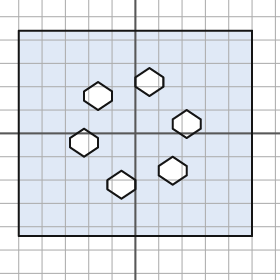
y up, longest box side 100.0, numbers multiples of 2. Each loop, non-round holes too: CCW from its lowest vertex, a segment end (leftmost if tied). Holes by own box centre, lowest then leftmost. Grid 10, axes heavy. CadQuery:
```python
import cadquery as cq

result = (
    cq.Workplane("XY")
    .moveTo(-50.0, -44.0)
    .lineTo(50.0, -44.0)
    .lineTo(50.0, 44.0)
    .lineTo(-50.0, 44.0)
    .close()
    .moveTo(-6.0, -28.0)
    .lineTo(0.0, -24.0)
    .lineTo(0.0, -20.0)
    .lineTo(-6.0, -16.0)
    .lineTo(-12.0, -20.0)
    .lineTo(-12.0, -24.0)
    .close()
    .moveTo(16.0, -22.0)
    .lineTo(22.0, -18.0)
    .lineTo(22.0, -14.0)
    .lineTo(16.0, -10.0)
    .lineTo(10.0, -14.0)
    .lineTo(10.0, -18.0)
    .close()
    .moveTo(-22.0, -10.0)
    .lineTo(-16.0, -6.0)
    .lineTo(-16.0, -2.0)
    .lineTo(-22.0, 2.0)
    .lineTo(-28.0, -2.0)
    .lineTo(-28.0, -6.0)
    .close()
    .moveTo(22.0, -2.0)
    .lineTo(28.0, 2.0)
    .lineTo(28.0, 6.0)
    .lineTo(22.0, 10.0)
    .lineTo(16.0, 6.0)
    .lineTo(16.0, 2.0)
    .close()
    .moveTo(-16.0, 10.0)
    .lineTo(-10.0, 14.0)
    .lineTo(-10.0, 18.0)
    .lineTo(-16.0, 22.0)
    .lineTo(-22.0, 18.0)
    .lineTo(-22.0, 14.0)
    .close()
    .moveTo(6.0, 16.0)
    .lineTo(12.0, 20.0)
    .lineTo(12.0, 24.0)
    .lineTo(6.0, 28.0)
    .lineTo(0.0, 24.0)
    .lineTo(0.0, 20.0)
    .close()
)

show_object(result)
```